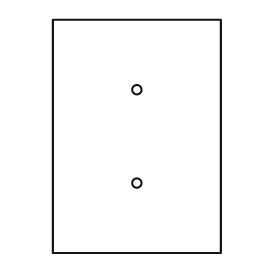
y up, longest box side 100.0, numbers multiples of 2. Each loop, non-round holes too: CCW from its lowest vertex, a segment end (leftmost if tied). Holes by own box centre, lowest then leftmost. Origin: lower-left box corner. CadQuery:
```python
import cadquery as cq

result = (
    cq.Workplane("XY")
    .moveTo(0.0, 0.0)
    .lineTo(72.0, 0.0)
    .lineTo(72.0, 100.0)
    .lineTo(0.0, 100.0)
    .close()
    .moveTo(36.0, 30.0)
    .circle(2.0)
    .moveTo(36.0, 70.0)
    .circle(2.0)
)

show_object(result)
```